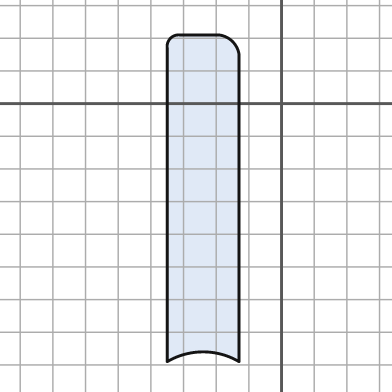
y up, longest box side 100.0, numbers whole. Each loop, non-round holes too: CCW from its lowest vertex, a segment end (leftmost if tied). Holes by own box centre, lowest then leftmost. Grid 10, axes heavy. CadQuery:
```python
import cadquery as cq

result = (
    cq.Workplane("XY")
    .moveTo(-35.0, -79.0)
    .threePointArc((-24.0, -76.0), (-13.0, -79.0))
    .lineTo(-13.0, 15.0)
    .threePointArc((-15.0, 19.0), (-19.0, 21.0))
    .lineTo(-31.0, 21.0)
    .threePointArc((-34.0, 20.0), (-35.0, 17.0))
    .close()
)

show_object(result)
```